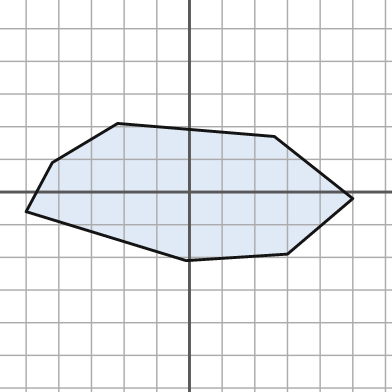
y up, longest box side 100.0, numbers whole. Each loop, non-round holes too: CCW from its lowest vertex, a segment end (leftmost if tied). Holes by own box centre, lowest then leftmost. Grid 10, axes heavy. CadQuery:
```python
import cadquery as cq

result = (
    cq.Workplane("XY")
    .moveTo(-1.0, -21.0)
    .lineTo(30.0, -19.0)
    .lineTo(50.0, -2.0)
    .lineTo(26.0, 17.0)
    .lineTo(-22.0, 21.0)
    .lineTo(-42.0, 9.0)
    .lineTo(-50.0, -6.0)
    .close()
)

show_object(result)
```